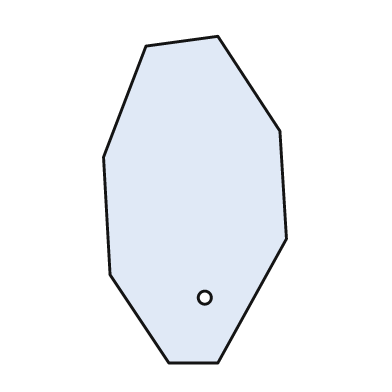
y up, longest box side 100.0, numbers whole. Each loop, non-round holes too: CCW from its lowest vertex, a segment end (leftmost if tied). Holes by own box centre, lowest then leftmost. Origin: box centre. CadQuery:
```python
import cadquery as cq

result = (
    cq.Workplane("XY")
    .moveTo(-8.0, -50.0)
    .lineTo(7.0, -50.0)
    .lineTo(28.0, -12.0)
    .lineTo(26.0, 21.0)
    .lineTo(7.0, 50.0)
    .lineTo(-15.0, 47.0)
    .lineTo(-28.0, 13.0)
    .lineTo(-26.0, -23.0)
    .close()
    .moveTo(3.0, -30.0)
    .circle(2.0)
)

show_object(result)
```